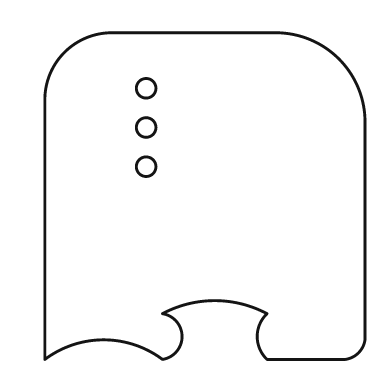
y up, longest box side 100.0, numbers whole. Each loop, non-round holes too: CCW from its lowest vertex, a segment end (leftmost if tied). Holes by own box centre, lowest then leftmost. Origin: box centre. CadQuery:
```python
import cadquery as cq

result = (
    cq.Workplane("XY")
    .moveTo(-49.0, -50.0)
    .threePointArc((-31.0, -44.0), (-13.0, -50.0))
    .threePointArc((-7.0, -43.0), (-13.0, -36.0))
    .threePointArc((3.0, -32.0), (19.0, -36.0))
    .threePointArc((16.0, -43.0), (19.0, -50.0))
    .lineTo(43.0, -50.0)
    .threePointArc((47.0, -48.0), (49.0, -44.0))
    .lineTo(49.0, 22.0)
    .threePointArc((41.0, 42.0), (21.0, 50.0))
    .lineTo(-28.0, 50.0)
    .threePointArc((-43.0, 44.0), (-49.0, 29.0))
    .close()
    .moveTo(-18.0, 9.0)
    .circle(3.0)
    .moveTo(-18.0, 21.0)
    .circle(3.0)
    .moveTo(-18.0, 33.0)
    .circle(3.0)
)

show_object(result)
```